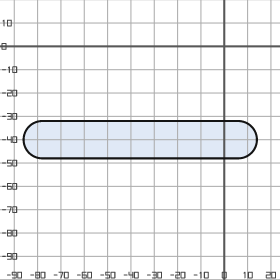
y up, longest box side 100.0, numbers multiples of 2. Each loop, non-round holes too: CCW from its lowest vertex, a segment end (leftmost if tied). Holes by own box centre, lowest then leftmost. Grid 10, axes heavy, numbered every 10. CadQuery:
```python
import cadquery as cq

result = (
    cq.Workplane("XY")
    .moveTo(-78.0, -48.0)
    .lineTo(6.0, -48.0)
    .threePointArc((14.0, -40.0), (6.0, -32.0))
    .lineTo(-78.0, -32.0)
    .threePointArc((-86.0, -40.0), (-78.0, -48.0))
    .close()
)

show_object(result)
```